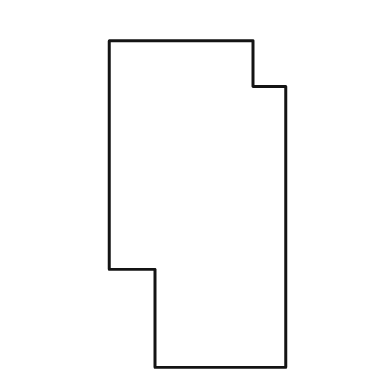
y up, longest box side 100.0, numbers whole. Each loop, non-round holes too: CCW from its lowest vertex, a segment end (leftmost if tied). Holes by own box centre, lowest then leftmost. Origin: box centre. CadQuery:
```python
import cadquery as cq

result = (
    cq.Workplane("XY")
    .moveTo(-13.0, -50.0)
    .lineTo(27.0, -50.0)
    .lineTo(27.0, 36.0)
    .lineTo(17.0, 36.0)
    .lineTo(17.0, 50.0)
    .lineTo(-27.0, 50.0)
    .lineTo(-27.0, -20.0)
    .lineTo(-13.0, -20.0)
    .close()
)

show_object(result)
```